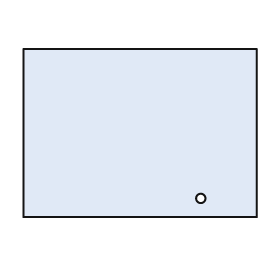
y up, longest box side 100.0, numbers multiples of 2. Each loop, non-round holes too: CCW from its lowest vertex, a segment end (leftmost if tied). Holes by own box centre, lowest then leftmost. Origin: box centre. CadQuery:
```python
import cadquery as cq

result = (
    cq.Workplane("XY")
    .moveTo(-50.0, -36.0)
    .lineTo(50.0, -36.0)
    .lineTo(50.0, 36.0)
    .lineTo(-50.0, 36.0)
    .close()
    .moveTo(26.0, -28.0)
    .circle(2.0)
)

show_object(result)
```